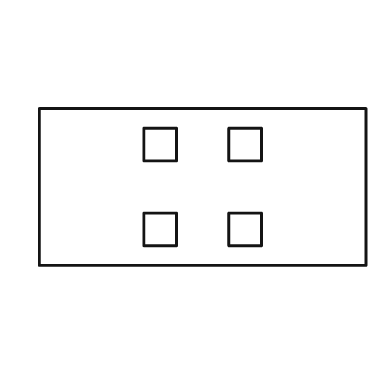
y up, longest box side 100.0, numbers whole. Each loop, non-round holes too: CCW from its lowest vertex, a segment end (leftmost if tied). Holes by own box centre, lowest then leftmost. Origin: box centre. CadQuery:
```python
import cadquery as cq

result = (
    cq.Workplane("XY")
    .moveTo(-50.0, -24.0)
    .lineTo(50.0, -24.0)
    .lineTo(50.0, 24.0)
    .lineTo(-50.0, 24.0)
    .close()
    .moveTo(-18.0, -18.0)
    .lineTo(-8.0, -18.0)
    .lineTo(-8.0, -8.0)
    .lineTo(-18.0, -8.0)
    .close()
    .moveTo(8.0, -18.0)
    .lineTo(18.0, -18.0)
    .lineTo(18.0, -8.0)
    .lineTo(8.0, -8.0)
    .close()
    .moveTo(-18.0, 8.0)
    .lineTo(-8.0, 8.0)
    .lineTo(-8.0, 18.0)
    .lineTo(-18.0, 18.0)
    .close()
    .moveTo(8.0, 8.0)
    .lineTo(18.0, 8.0)
    .lineTo(18.0, 18.0)
    .lineTo(8.0, 18.0)
    .close()
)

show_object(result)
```